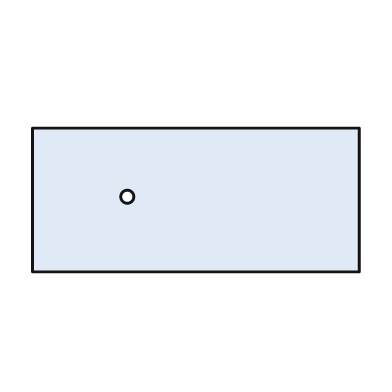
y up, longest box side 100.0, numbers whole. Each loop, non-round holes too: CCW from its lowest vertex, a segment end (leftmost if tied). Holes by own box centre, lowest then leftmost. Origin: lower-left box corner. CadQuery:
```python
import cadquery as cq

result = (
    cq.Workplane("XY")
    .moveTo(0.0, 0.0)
    .lineTo(100.0, 0.0)
    .lineTo(100.0, 44.0)
    .lineTo(0.0, 44.0)
    .close()
    .moveTo(29.0, 23.0)
    .circle(2.0)
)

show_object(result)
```